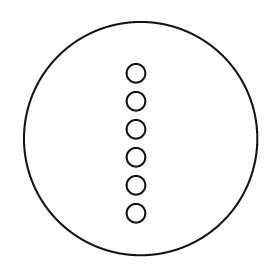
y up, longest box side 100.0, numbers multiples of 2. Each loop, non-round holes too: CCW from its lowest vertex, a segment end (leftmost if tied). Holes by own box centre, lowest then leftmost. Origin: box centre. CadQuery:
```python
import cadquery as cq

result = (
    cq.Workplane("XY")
    .moveTo(0.0, 0.0)
    .circle(50.0)
    .moveTo(-2.0, -32.0)
    .circle(4.0)
    .moveTo(-2.0, -20.0)
    .circle(4.0)
    .moveTo(-2.0, -8.0)
    .circle(4.0)
    .moveTo(-2.0, 4.0)
    .circle(4.0)
    .moveTo(-2.0, 16.0)
    .circle(4.0)
    .moveTo(-2.0, 28.0)
    .circle(4.0)
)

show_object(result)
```